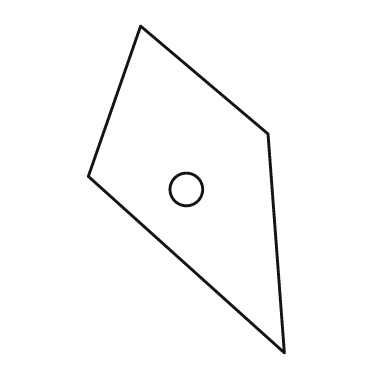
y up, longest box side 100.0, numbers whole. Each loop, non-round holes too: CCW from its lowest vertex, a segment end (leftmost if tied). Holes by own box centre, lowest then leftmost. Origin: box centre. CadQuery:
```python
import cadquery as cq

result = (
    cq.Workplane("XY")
    .moveTo(30.0, -50.0)
    .lineTo(25.0, 17.0)
    .lineTo(-14.0, 50.0)
    .lineTo(-30.0, 4.0)
    .close()
    .moveTo(0.0, 0.0)
    .circle(5.0)
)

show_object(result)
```